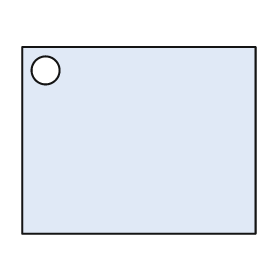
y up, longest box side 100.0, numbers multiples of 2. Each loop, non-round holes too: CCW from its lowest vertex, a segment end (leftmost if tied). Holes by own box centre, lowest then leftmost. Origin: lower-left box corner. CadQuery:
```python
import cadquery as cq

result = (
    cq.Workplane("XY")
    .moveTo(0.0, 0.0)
    .lineTo(100.0, 0.0)
    .lineTo(100.0, 80.0)
    .lineTo(0.0, 80.0)
    .close()
    .moveTo(10.0, 70.0)
    .circle(6.0)
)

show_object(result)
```